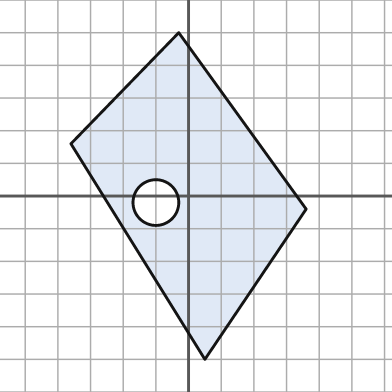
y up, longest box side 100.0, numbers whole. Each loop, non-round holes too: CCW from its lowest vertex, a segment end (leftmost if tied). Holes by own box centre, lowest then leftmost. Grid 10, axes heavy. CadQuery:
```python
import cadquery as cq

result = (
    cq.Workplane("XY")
    .moveTo(5.0, -50.0)
    .lineTo(36.0, -4.0)
    .lineTo(-3.0, 50.0)
    .lineTo(-36.0, 16.0)
    .close()
    .moveTo(-10.0, -2.0)
    .circle(7.0)
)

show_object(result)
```